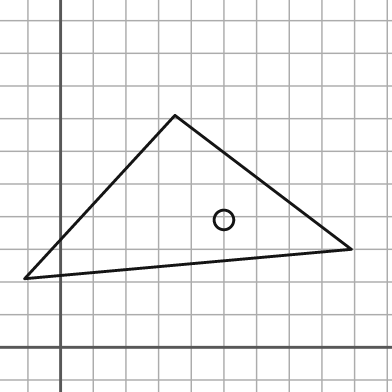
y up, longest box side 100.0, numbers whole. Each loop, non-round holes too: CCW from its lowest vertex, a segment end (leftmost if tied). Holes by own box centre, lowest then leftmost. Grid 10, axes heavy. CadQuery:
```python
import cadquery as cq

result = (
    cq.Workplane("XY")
    .moveTo(-11.0, 21.0)
    .lineTo(89.0, 30.0)
    .lineTo(35.0, 71.0)
    .close()
    .moveTo(50.0, 39.0)
    .circle(3.0)
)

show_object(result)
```